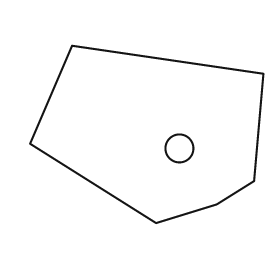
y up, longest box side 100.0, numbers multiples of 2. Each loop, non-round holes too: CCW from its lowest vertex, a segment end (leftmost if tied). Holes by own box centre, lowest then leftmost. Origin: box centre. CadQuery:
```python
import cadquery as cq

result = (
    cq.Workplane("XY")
    .moveTo(4.0, -38.0)
    .lineTo(30.0, -30.0)
    .lineTo(46.0, -20.0)
    .lineTo(50.0, 26.0)
    .lineTo(-32.0, 38.0)
    .lineTo(-50.0, -4.0)
    .close()
    .moveTo(14.0, -6.0)
    .circle(6.0)
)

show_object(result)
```